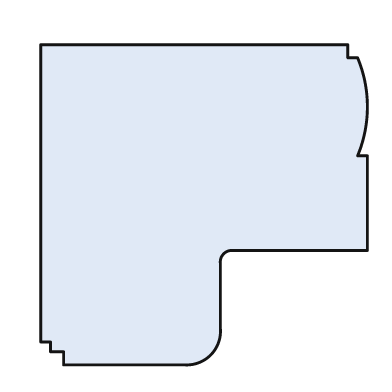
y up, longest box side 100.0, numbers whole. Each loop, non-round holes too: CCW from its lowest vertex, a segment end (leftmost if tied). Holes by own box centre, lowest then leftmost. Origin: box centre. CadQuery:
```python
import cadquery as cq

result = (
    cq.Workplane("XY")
    .moveTo(-43.0, -49.0)
    .lineTo(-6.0, -49.0)
    .threePointArc((2.0, -46.0), (5.0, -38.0))
    .lineTo(5.0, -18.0)
    .threePointArc((6.0, -15.0), (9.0, -14.0))
    .lineTo(50.0, -14.0)
    .lineTo(50.0, 15.0)
    .lineTo(47.0, 15.0)
    .threePointArc((50.0, 30.0), (47.0, 45.0))
    .lineTo(44.0, 45.0)
    .lineTo(44.0, 49.0)
    .lineTo(-50.0, 49.0)
    .lineTo(-50.0, -42.0)
    .lineTo(-47.0, -42.0)
    .lineTo(-47.0, -45.0)
    .lineTo(-43.0, -45.0)
    .close()
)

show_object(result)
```